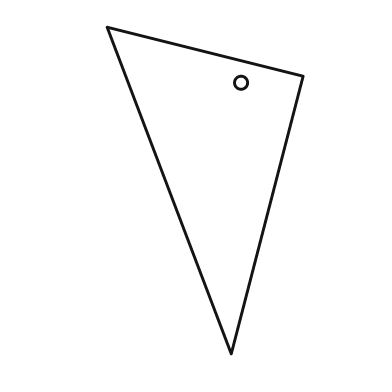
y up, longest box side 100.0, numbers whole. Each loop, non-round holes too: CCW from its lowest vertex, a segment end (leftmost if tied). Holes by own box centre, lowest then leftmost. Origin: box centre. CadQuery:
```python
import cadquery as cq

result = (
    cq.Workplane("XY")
    .moveTo(8.0, -50.0)
    .lineTo(30.0, 35.0)
    .lineTo(-30.0, 50.0)
    .close()
    .moveTo(11.0, 33.0)
    .circle(2.0)
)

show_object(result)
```